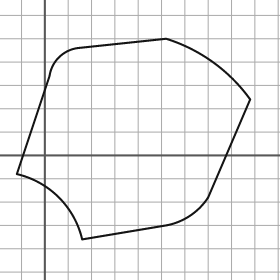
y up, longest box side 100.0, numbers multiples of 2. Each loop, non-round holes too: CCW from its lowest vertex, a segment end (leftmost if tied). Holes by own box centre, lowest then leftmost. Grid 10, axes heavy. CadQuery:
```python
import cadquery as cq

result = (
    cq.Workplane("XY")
    .moveTo(16.0, -36.0)
    .lineTo(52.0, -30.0)
    .threePointArc((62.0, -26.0), (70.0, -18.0))
    .lineTo(88.0, 24.0)
    .threePointArc((72.0, 40.0), (52.0, 50.0))
    .lineTo(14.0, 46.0)
    .threePointArc((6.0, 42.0), (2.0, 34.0))
    .lineTo(-12.0, -8.0)
    .threePointArc((6.0, -18.0), (16.0, -36.0))
    .close()
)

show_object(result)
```